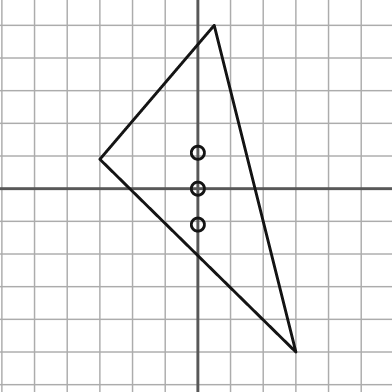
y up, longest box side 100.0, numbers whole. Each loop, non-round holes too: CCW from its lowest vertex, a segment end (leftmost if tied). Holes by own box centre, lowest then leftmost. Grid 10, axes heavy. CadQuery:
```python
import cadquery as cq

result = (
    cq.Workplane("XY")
    .moveTo(30.0, -50.0)
    .lineTo(5.0, 50.0)
    .lineTo(-30.0, 9.0)
    .close()
    .moveTo(0.0, -11.0)
    .circle(2.0)
    .moveTo(0.0, 0.0)
    .circle(2.0)
    .moveTo(0.0, 11.0)
    .circle(2.0)
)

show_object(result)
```